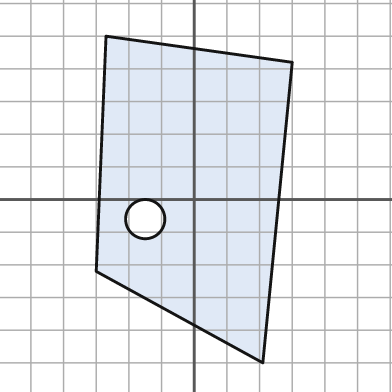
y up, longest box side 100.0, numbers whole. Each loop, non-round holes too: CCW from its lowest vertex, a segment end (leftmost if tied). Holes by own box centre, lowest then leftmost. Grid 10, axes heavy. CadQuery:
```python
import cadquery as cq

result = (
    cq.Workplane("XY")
    .moveTo(21.0, -50.0)
    .lineTo(30.0, 42.0)
    .lineTo(-27.0, 50.0)
    .lineTo(-30.0, -22.0)
    .close()
    .moveTo(-15.0, -6.0)
    .circle(6.0)
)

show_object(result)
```